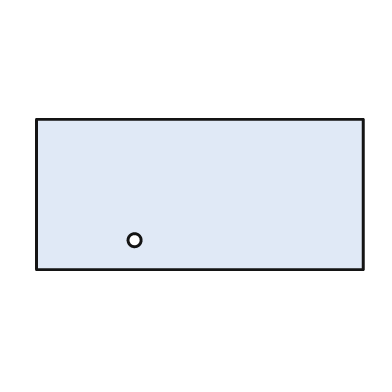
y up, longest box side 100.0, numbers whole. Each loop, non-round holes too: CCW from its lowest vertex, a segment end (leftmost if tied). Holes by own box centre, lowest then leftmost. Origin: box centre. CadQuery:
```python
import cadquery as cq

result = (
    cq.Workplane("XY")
    .moveTo(-50.0, -23.0)
    .lineTo(50.0, -23.0)
    .lineTo(50.0, 23.0)
    .lineTo(-50.0, 23.0)
    .close()
    .moveTo(-20.0, -14.0)
    .circle(2.0)
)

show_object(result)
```